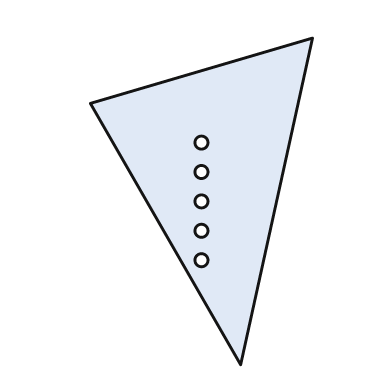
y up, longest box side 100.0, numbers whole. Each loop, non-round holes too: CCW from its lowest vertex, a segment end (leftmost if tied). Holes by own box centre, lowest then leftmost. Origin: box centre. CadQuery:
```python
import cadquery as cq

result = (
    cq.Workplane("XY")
    .moveTo(12.0, -50.0)
    .lineTo(34.0, 50.0)
    .lineTo(-34.0, 30.0)
    .close()
    .moveTo(0.0, -18.0)
    .circle(2.0)
    .moveTo(0.0, -9.0)
    .circle(2.0)
    .moveTo(0.0, 0.0)
    .circle(2.0)
    .moveTo(0.0, 9.0)
    .circle(2.0)
    .moveTo(0.0, 18.0)
    .circle(2.0)
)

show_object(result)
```